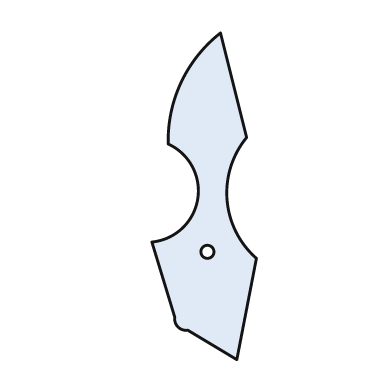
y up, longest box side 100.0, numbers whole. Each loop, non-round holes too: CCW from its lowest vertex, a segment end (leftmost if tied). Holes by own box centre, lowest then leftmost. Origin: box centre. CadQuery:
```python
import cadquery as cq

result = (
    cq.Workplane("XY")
    .moveTo(10.0, -50.0)
    .lineTo(16.0, -19.0)
    .threePointArc((7.0, -1.0), (13.0, 18.0))
    .lineTo(5.0, 50.0)
    .threePointArc((-7.0, 35.0), (-11.0, 16.0))
    .threePointArc((-2.0, -1.0), (-16.0, -14.0))
    .lineTo(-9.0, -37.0)
    .threePointArc((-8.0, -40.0), (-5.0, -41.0))
    .close()
    .moveTo(1.0, -17.0)
    .circle(2.0)
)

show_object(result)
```